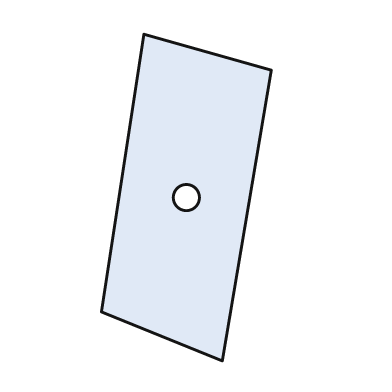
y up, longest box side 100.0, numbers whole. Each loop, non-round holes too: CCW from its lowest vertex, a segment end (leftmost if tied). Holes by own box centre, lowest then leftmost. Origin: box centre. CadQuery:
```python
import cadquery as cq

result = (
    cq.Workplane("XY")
    .moveTo(11.0, -50.0)
    .lineTo(26.0, 39.0)
    .lineTo(-13.0, 50.0)
    .lineTo(-26.0, -35.0)
    .close()
    .moveTo(0.0, 0.0)
    .circle(4.0)
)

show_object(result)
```